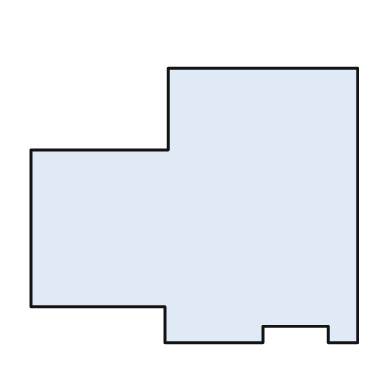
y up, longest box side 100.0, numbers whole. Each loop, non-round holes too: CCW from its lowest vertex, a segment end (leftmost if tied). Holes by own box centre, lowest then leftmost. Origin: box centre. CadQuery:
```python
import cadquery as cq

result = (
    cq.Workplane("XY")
    .moveTo(-9.0, -42.0)
    .lineTo(21.0, -42.0)
    .lineTo(21.0, -37.0)
    .lineTo(41.0, -37.0)
    .lineTo(41.0, -42.0)
    .lineTo(50.0, -42.0)
    .lineTo(50.0, 42.0)
    .lineTo(-8.0, 42.0)
    .lineTo(-8.0, 17.0)
    .lineTo(-50.0, 17.0)
    .lineTo(-50.0, -31.0)
    .lineTo(-9.0, -31.0)
    .close()
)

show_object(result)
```